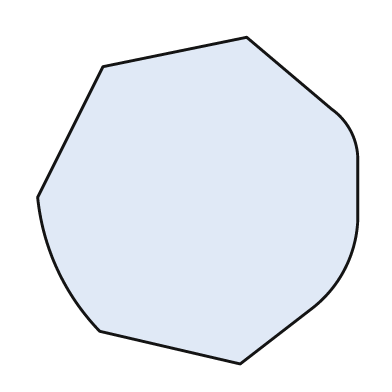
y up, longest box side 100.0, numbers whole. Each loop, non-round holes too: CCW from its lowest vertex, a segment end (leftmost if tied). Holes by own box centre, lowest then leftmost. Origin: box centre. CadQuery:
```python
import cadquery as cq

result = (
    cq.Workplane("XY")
    .moveTo(13.0, -50.0)
    .lineTo(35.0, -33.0)
    .threePointArc((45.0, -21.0), (49.0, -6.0))
    .lineTo(49.0, 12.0)
    .threePointArc((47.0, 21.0), (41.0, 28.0))
    .lineTo(15.0, 50.0)
    .lineTo(-29.0, 41.0)
    .lineTo(-49.0, 1.0)
    .threePointArc((-43.0, -21.0), (-30.0, -40.0))
    .close()
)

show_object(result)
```